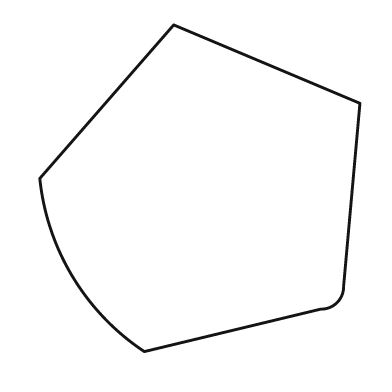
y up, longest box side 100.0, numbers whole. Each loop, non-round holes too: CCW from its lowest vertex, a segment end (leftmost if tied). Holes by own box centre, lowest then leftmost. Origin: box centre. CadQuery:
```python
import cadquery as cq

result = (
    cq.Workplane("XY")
    .moveTo(-17.0, -50.0)
    .lineTo(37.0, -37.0)
    .threePointArc((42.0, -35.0), (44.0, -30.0))
    .lineTo(49.0, 26.0)
    .lineTo(-8.0, 50.0)
    .lineTo(-49.0, 3.0)
    .threePointArc((-39.0, -27.0), (-17.0, -50.0))
    .close()
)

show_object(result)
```